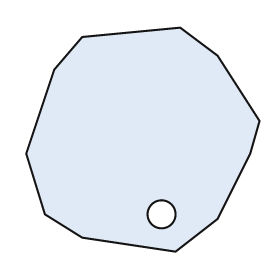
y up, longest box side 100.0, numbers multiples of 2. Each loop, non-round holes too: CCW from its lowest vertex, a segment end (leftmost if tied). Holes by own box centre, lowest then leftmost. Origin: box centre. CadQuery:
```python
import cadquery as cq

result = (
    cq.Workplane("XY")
    .moveTo(14.0, -48.0)
    .lineTo(32.0, -34.0)
    .lineTo(46.0, -6.0)
    .lineTo(50.0, 8.0)
    .lineTo(32.0, 36.0)
    .lineTo(16.0, 48.0)
    .lineTo(-26.0, 44.0)
    .lineTo(-38.0, 30.0)
    .lineTo(-50.0, -6.0)
    .lineTo(-42.0, -32.0)
    .lineTo(-26.0, -42.0)
    .close()
    .moveTo(8.0, -32.0)
    .circle(6.0)
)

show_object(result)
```